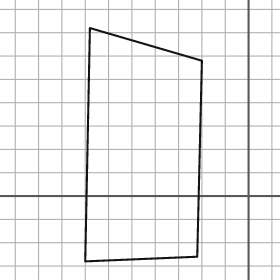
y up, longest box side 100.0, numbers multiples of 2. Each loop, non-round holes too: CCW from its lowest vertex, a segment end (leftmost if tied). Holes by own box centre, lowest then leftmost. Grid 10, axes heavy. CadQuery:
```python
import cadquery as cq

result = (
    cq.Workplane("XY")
    .moveTo(-70.0, -28.0)
    .lineTo(-22.0, -26.0)
    .lineTo(-20.0, 58.0)
    .lineTo(-68.0, 72.0)
    .close()
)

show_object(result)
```